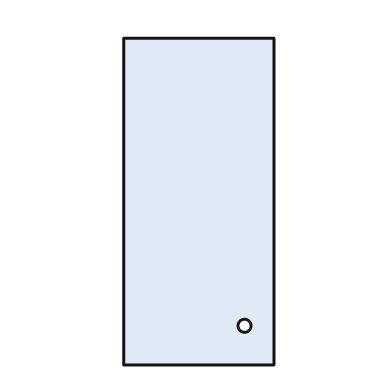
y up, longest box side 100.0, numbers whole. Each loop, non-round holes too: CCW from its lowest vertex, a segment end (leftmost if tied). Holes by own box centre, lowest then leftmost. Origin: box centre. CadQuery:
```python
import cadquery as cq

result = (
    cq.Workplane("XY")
    .moveTo(-23.0, -50.0)
    .lineTo(23.0, -50.0)
    .lineTo(23.0, 50.0)
    .lineTo(-23.0, 50.0)
    .close()
    .moveTo(14.0, -38.0)
    .circle(2.0)
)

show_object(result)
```